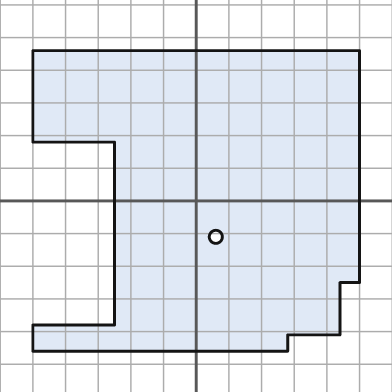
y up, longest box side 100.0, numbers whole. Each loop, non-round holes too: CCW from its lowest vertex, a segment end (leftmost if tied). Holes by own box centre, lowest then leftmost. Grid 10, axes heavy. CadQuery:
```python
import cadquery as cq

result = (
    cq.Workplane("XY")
    .moveTo(-50.0, -46.0)
    .lineTo(28.0, -46.0)
    .lineTo(28.0, -41.0)
    .lineTo(44.0, -41.0)
    .lineTo(44.0, -25.0)
    .lineTo(50.0, -25.0)
    .lineTo(50.0, 46.0)
    .lineTo(-50.0, 46.0)
    .lineTo(-50.0, 18.0)
    .lineTo(-25.0, 18.0)
    .lineTo(-25.0, -38.0)
    .lineTo(-50.0, -38.0)
    .close()
    .moveTo(6.0, -11.0)
    .circle(2.0)
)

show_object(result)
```